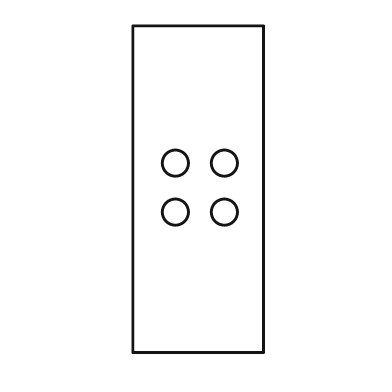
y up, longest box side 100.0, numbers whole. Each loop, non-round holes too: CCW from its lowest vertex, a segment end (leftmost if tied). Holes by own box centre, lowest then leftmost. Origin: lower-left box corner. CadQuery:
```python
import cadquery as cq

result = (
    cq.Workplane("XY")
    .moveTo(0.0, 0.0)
    .lineTo(40.0, 0.0)
    .lineTo(40.0, 100.0)
    .lineTo(0.0, 100.0)
    .close()
    .moveTo(13.0, 43.0)
    .circle(4.0)
    .moveTo(28.0, 43.0)
    .circle(4.0)
    .moveTo(13.0, 58.0)
    .circle(4.0)
    .moveTo(28.0, 58.0)
    .circle(4.0)
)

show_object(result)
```